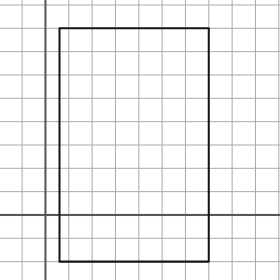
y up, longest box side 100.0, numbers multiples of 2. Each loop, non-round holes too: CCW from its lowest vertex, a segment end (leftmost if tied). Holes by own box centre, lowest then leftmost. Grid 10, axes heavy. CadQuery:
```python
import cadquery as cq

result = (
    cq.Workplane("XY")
    .moveTo(6.0, -20.0)
    .lineTo(70.0, -20.0)
    .lineTo(70.0, 80.0)
    .lineTo(6.0, 80.0)
    .close()
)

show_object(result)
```